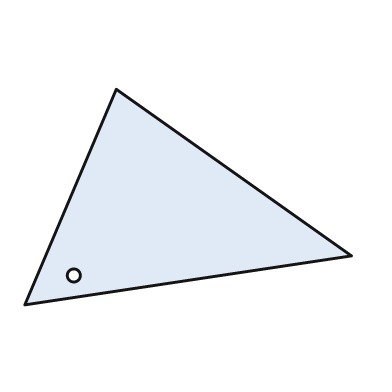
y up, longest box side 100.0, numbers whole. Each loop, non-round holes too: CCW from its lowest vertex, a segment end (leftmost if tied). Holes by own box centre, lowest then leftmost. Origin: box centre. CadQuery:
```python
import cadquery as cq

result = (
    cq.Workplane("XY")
    .moveTo(-50.0, -33.0)
    .lineTo(50.0, -18.0)
    .lineTo(-22.0, 33.0)
    .close()
    .moveTo(-35.0, -24.0)
    .circle(2.0)
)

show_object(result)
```